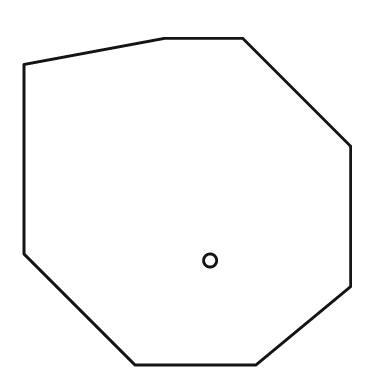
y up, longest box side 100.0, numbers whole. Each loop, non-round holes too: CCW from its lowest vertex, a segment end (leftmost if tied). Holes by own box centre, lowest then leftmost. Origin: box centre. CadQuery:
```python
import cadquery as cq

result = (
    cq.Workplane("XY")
    .moveTo(-16.0, -50.0)
    .lineTo(21.0, -50.0)
    .lineTo(50.0, -26.0)
    .lineTo(50.0, 17.0)
    .lineTo(17.0, 50.0)
    .lineTo(-7.0, 50.0)
    .lineTo(-50.0, 42.0)
    .lineTo(-50.0, -16.0)
    .close()
    .moveTo(7.0, -18.0)
    .circle(2.0)
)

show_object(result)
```